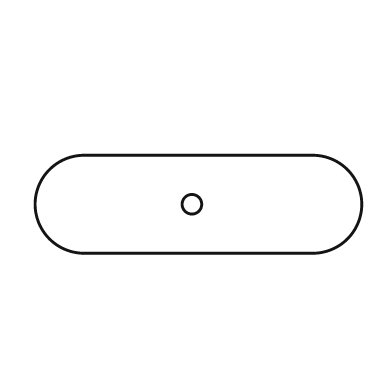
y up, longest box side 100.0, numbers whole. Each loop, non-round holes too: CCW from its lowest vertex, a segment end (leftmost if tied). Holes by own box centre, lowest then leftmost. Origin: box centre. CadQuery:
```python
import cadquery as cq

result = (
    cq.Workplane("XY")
    .moveTo(-35.0, -15.0)
    .lineTo(35.0, -15.0)
    .threePointArc((50.0, 0.0), (35.0, 15.0))
    .lineTo(-35.0, 15.0)
    .threePointArc((-50.0, 0.0), (-35.0, -15.0))
    .close()
    .moveTo(-2.0, 0.0)
    .circle(3.0)
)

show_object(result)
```